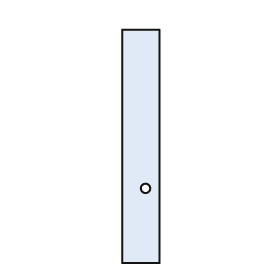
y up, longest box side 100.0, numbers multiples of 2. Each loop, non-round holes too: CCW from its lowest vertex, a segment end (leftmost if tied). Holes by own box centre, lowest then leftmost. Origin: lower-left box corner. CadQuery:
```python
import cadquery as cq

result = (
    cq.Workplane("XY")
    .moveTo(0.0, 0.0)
    .lineTo(16.0, 0.0)
    .lineTo(16.0, 100.0)
    .lineTo(0.0, 100.0)
    .close()
    .moveTo(10.0, 32.0)
    .circle(2.0)
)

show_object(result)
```